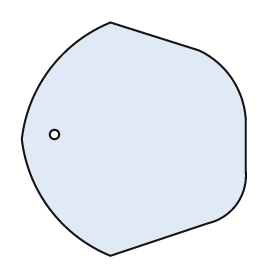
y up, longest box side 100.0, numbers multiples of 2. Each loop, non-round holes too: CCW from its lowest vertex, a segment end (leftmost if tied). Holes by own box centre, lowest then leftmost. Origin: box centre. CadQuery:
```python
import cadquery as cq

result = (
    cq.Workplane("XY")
    .moveTo(-10.0, -50.0)
    .lineTo(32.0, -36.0)
    .threePointArc((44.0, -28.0), (48.0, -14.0))
    .lineTo(48.0, 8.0)
    .threePointArc((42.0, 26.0), (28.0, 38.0))
    .lineTo(-10.0, 50.0)
    .threePointArc((-36.0, 30.0), (-48.0, 0.0))
    .threePointArc((-36.0, -30.0), (-10.0, -50.0))
    .close()
    .moveTo(-34.0, 2.0)
    .circle(2.0)
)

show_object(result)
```